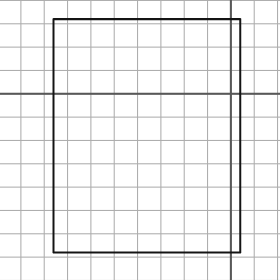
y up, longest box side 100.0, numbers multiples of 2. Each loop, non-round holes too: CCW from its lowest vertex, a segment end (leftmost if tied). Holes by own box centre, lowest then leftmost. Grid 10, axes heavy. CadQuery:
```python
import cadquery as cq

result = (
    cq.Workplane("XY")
    .moveTo(-76.0, -68.0)
    .lineTo(4.0, -68.0)
    .lineTo(4.0, 32.0)
    .lineTo(-76.0, 32.0)
    .close()
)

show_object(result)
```